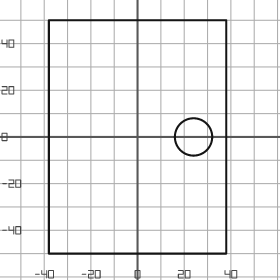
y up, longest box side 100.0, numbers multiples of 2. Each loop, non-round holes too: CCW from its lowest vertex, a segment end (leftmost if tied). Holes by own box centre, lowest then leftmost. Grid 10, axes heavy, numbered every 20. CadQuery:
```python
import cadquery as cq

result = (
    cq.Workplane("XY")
    .moveTo(-38.0, -50.0)
    .lineTo(38.0, -50.0)
    .lineTo(38.0, 50.0)
    .lineTo(-38.0, 50.0)
    .close()
    .moveTo(24.0, 0.0)
    .circle(8.0)
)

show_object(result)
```